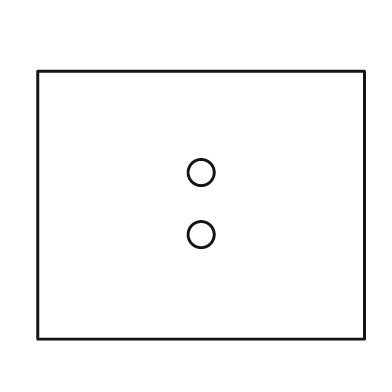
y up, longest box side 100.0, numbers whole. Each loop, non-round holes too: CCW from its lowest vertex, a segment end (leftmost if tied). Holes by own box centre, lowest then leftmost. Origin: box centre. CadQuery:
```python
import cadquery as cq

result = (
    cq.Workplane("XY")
    .moveTo(-50.0, -41.0)
    .lineTo(50.0, -41.0)
    .lineTo(50.0, 41.0)
    .lineTo(-50.0, 41.0)
    .close()
    .moveTo(0.0, -9.0)
    .circle(4.0)
    .moveTo(0.0, 10.0)
    .circle(4.0)
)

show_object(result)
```